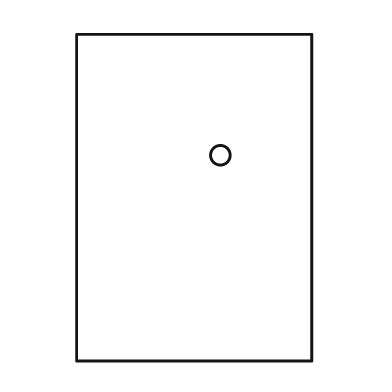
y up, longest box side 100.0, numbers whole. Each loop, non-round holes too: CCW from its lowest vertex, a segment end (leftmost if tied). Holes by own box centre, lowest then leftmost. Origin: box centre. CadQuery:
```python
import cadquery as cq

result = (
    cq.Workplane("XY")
    .moveTo(-36.0, -50.0)
    .lineTo(36.0, -50.0)
    .lineTo(36.0, 50.0)
    .lineTo(-36.0, 50.0)
    .close()
    .moveTo(8.0, 13.0)
    .circle(3.0)
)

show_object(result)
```